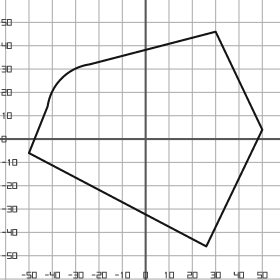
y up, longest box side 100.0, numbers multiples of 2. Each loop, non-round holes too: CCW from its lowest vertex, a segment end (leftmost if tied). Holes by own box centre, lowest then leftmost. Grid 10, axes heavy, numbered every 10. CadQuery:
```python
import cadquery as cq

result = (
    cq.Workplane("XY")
    .moveTo(26.0, -46.0)
    .lineTo(50.0, 4.0)
    .lineTo(30.0, 46.0)
    .lineTo(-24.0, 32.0)
    .threePointArc((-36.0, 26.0), (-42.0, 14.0))
    .lineTo(-50.0, -6.0)
    .close()
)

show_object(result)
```